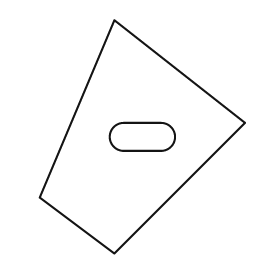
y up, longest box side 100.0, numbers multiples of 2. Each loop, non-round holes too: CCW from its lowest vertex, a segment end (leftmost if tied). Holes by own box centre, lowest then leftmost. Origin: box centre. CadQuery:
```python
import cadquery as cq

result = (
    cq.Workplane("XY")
    .moveTo(-12.0, -50.0)
    .lineTo(44.0, 6.0)
    .lineTo(-12.0, 50.0)
    .lineTo(-44.0, -26.0)
    .close()
    .moveTo(-8.0, -6.0)
    .lineTo(8.0, -6.0)
    .threePointArc((14.0, 0.0), (8.0, 6.0))
    .lineTo(-8.0, 6.0)
    .threePointArc((-14.0, 0.0), (-8.0, -6.0))
    .close()
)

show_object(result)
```